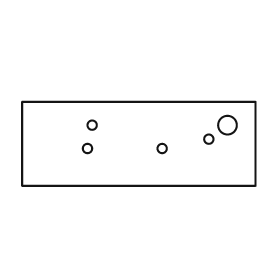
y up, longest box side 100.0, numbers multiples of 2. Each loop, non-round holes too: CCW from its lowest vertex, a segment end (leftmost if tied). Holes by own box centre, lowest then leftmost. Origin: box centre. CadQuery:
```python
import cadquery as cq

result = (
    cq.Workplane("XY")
    .moveTo(-50.0, -18.0)
    .lineTo(50.0, -18.0)
    .lineTo(50.0, 18.0)
    .lineTo(-50.0, 18.0)
    .close()
    .moveTo(-22.0, -2.0)
    .circle(2.0)
    .moveTo(10.0, -2.0)
    .circle(2.0)
    .moveTo(30.0, 2.0)
    .circle(2.0)
    .moveTo(-20.0, 8.0)
    .circle(2.0)
    .moveTo(38.0, 8.0)
    .circle(4.0)
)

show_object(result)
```